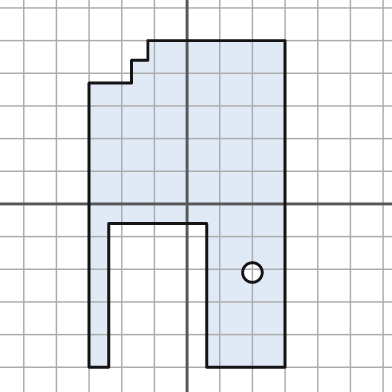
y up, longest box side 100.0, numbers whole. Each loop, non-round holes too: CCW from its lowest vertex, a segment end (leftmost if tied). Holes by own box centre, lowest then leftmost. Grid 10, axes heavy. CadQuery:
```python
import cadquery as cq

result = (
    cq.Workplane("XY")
    .moveTo(-30.0, -50.0)
    .lineTo(-24.0, -50.0)
    .lineTo(-24.0, -6.0)
    .lineTo(6.0, -6.0)
    .lineTo(6.0, -50.0)
    .lineTo(30.0, -50.0)
    .lineTo(30.0, 50.0)
    .lineTo(-12.0, 50.0)
    .lineTo(-12.0, 44.0)
    .lineTo(-17.0, 44.0)
    .lineTo(-17.0, 37.0)
    .lineTo(-30.0, 37.0)
    .close()
    .moveTo(20.0, -21.0)
    .circle(3.0)
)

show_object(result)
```